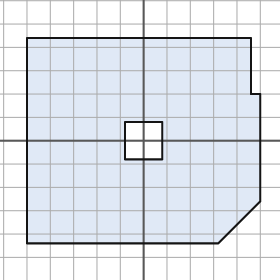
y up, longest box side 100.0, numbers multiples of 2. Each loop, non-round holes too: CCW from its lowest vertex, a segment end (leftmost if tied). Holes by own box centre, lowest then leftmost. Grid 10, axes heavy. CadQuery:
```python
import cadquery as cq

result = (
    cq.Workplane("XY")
    .moveTo(-50.0, -44.0)
    .lineTo(32.0, -44.0)
    .lineTo(50.0, -26.0)
    .lineTo(50.0, 20.0)
    .lineTo(46.0, 20.0)
    .lineTo(46.0, 44.0)
    .lineTo(-50.0, 44.0)
    .close()
    .moveTo(-8.0, -8.0)
    .lineTo(8.0, -8.0)
    .lineTo(8.0, 8.0)
    .lineTo(-8.0, 8.0)
    .close()
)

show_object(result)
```